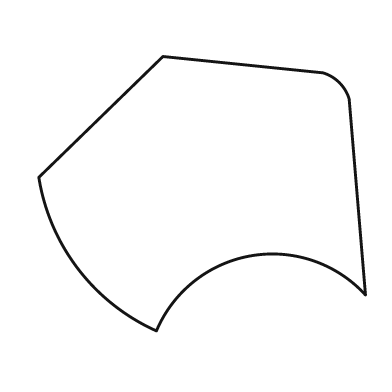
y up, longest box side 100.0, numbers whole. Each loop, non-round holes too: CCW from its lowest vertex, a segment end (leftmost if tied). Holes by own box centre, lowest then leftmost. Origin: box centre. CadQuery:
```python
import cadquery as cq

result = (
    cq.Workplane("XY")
    .moveTo(-14.0, -42.0)
    .threePointArc((15.0, -19.0), (50.0, -31.0))
    .lineTo(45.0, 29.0)
    .threePointArc((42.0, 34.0), (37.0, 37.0))
    .lineTo(-12.0, 42.0)
    .lineTo(-50.0, 5.0)
    .threePointArc((-38.0, -23.0), (-14.0, -42.0))
    .close()
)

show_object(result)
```